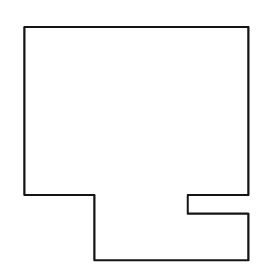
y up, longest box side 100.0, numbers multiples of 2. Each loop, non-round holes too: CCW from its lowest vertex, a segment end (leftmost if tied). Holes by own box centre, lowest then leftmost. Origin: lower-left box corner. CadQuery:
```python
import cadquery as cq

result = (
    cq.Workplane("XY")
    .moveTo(30.0, 0.0)
    .lineTo(96.0, 0.0)
    .lineTo(96.0, 20.0)
    .lineTo(70.0, 20.0)
    .lineTo(70.0, 28.0)
    .lineTo(96.0, 28.0)
    .lineTo(96.0, 100.0)
    .lineTo(0.0, 100.0)
    .lineTo(0.0, 28.0)
    .lineTo(30.0, 28.0)
    .close()
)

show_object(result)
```